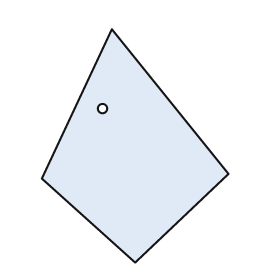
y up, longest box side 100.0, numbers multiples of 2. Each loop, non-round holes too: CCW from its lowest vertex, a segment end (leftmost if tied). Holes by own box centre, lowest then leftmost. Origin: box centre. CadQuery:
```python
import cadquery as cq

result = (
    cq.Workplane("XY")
    .moveTo(0.0, -50.0)
    .lineTo(40.0, -12.0)
    .lineTo(-10.0, 50.0)
    .lineTo(-40.0, -14.0)
    .close()
    .moveTo(-14.0, 16.0)
    .circle(2.0)
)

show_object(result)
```